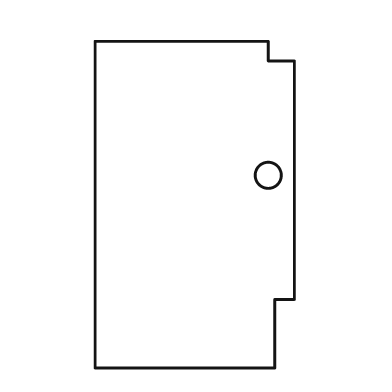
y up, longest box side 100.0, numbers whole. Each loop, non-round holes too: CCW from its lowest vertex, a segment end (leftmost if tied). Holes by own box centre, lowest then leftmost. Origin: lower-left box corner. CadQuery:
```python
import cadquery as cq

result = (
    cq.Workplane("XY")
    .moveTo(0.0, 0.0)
    .lineTo(55.0, 0.0)
    .lineTo(55.0, 21.0)
    .lineTo(61.0, 21.0)
    .lineTo(61.0, 94.0)
    .lineTo(53.0, 94.0)
    .lineTo(53.0, 100.0)
    .lineTo(0.0, 100.0)
    .close()
    .moveTo(53.0, 59.0)
    .circle(4.0)
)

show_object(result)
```